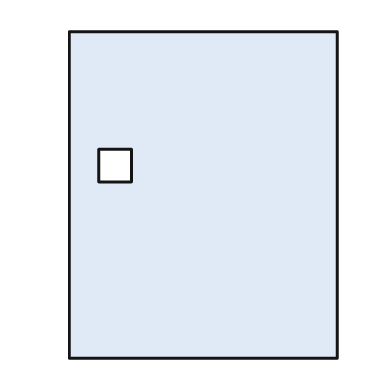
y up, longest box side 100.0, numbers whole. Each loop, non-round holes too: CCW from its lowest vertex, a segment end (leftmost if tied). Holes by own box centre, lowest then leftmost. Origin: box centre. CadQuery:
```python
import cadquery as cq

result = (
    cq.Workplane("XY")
    .moveTo(-41.0, -50.0)
    .lineTo(41.0, -50.0)
    .lineTo(41.0, 50.0)
    .lineTo(-41.0, 50.0)
    .close()
    .moveTo(-32.0, 4.0)
    .lineTo(-22.0, 4.0)
    .lineTo(-22.0, 14.0)
    .lineTo(-32.0, 14.0)
    .close()
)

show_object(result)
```